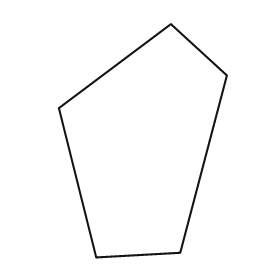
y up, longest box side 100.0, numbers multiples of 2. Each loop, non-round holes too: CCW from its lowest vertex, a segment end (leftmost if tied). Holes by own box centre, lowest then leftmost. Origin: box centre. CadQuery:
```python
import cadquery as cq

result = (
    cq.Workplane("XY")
    .moveTo(-20.0, -50.0)
    .lineTo(16.0, -48.0)
    .lineTo(36.0, 28.0)
    .lineTo(12.0, 50.0)
    .lineTo(-36.0, 14.0)
    .close()
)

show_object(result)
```